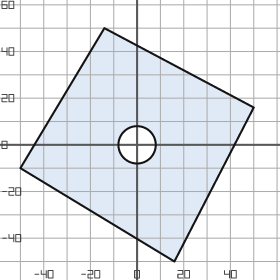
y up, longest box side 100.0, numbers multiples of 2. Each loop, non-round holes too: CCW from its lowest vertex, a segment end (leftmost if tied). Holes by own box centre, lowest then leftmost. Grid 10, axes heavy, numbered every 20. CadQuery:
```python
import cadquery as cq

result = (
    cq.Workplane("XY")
    .moveTo(16.0, -50.0)
    .lineTo(50.0, 16.0)
    .lineTo(-14.0, 50.0)
    .lineTo(-50.0, -10.0)
    .close()
    .moveTo(0.0, 0.0)
    .circle(8.0)
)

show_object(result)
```